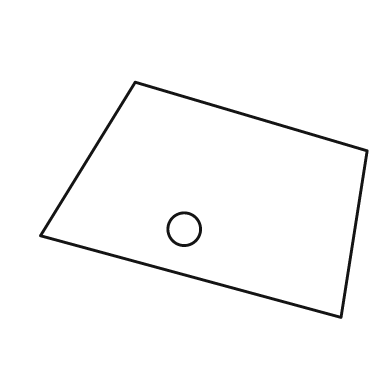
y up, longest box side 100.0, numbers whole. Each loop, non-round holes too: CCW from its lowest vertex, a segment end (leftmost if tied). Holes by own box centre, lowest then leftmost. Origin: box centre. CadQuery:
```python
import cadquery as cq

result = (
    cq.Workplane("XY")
    .moveTo(42.0, -36.0)
    .lineTo(50.0, 15.0)
    .lineTo(-21.0, 36.0)
    .lineTo(-50.0, -11.0)
    .close()
    .moveTo(-6.0, -9.0)
    .circle(5.0)
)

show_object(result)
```